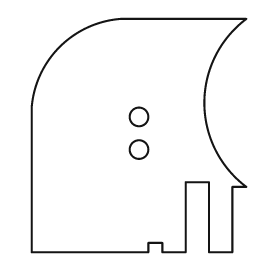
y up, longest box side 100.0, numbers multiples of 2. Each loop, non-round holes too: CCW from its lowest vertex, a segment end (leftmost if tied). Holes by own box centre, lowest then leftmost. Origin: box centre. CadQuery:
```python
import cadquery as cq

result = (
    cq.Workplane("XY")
    .moveTo(-46.0, -50.0)
    .lineTo(4.0, -50.0)
    .lineTo(4.0, -46.0)
    .lineTo(10.0, -46.0)
    .lineTo(10.0, -50.0)
    .lineTo(20.0, -50.0)
    .lineTo(20.0, -20.0)
    .lineTo(30.0, -20.0)
    .lineTo(30.0, -50.0)
    .lineTo(40.0, -50.0)
    .lineTo(40.0, -22.0)
    .lineTo(46.0, -22.0)
    .threePointArc((28.0, 14.0), (46.0, 50.0))
    .lineTo(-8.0, 50.0)
    .threePointArc((-34.0, 38.0), (-46.0, 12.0))
    .close()
    .moveTo(0.0, -6.0)
    .circle(4.0)
    .moveTo(0.0, 8.0)
    .circle(4.0)
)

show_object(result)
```